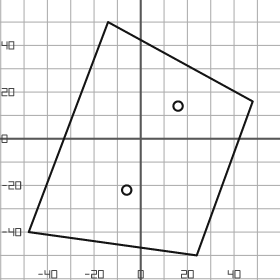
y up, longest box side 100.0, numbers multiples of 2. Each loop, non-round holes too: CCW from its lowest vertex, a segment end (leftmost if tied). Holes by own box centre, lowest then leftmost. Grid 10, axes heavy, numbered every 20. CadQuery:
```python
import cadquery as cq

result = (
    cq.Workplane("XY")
    .moveTo(24.0, -50.0)
    .lineTo(48.0, 16.0)
    .lineTo(-14.0, 50.0)
    .lineTo(-48.0, -40.0)
    .close()
    .moveTo(-6.0, -22.0)
    .circle(2.0)
    .moveTo(16.0, 14.0)
    .circle(2.0)
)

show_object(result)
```